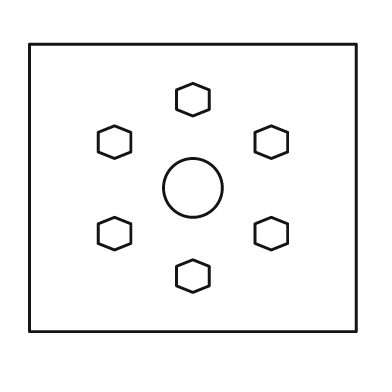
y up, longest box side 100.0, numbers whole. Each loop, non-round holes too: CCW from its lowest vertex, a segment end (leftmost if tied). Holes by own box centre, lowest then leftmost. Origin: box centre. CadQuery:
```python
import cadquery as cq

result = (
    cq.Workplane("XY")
    .moveTo(-50.0, -44.0)
    .lineTo(50.0, -44.0)
    .lineTo(50.0, 44.0)
    .lineTo(-50.0, 44.0)
    .close()
    .moveTo(0.0, -32.0)
    .lineTo(5.0, -30.0)
    .lineTo(5.0, -24.0)
    .lineTo(0.0, -22.0)
    .lineTo(-5.0, -24.0)
    .lineTo(-5.0, -30.0)
    .close()
    .moveTo(-24.0, -19.0)
    .lineTo(-19.0, -17.0)
    .lineTo(-19.0, -11.0)
    .lineTo(-24.0, -9.0)
    .lineTo(-29.0, -11.0)
    .lineTo(-29.0, -17.0)
    .close()
    .moveTo(24.0, -19.0)
    .lineTo(29.0, -17.0)
    .lineTo(29.0, -11.0)
    .lineTo(24.0, -9.0)
    .lineTo(19.0, -11.0)
    .lineTo(19.0, -17.0)
    .close()
    .moveTo(0.0, 0.0)
    .circle(9.0)
    .moveTo(-24.0, 9.0)
    .lineTo(-19.0, 11.0)
    .lineTo(-19.0, 17.0)
    .lineTo(-24.0, 19.0)
    .lineTo(-29.0, 17.0)
    .lineTo(-29.0, 11.0)
    .close()
    .moveTo(24.0, 9.0)
    .lineTo(29.0, 11.0)
    .lineTo(29.0, 17.0)
    .lineTo(24.0, 19.0)
    .lineTo(19.0, 17.0)
    .lineTo(19.0, 11.0)
    .close()
    .moveTo(0.0, 22.0)
    .lineTo(5.0, 24.0)
    .lineTo(5.0, 30.0)
    .lineTo(0.0, 32.0)
    .lineTo(-5.0, 30.0)
    .lineTo(-5.0, 24.0)
    .close()
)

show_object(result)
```